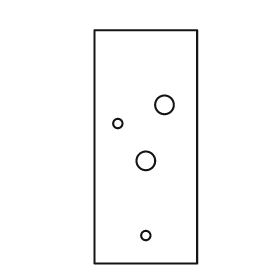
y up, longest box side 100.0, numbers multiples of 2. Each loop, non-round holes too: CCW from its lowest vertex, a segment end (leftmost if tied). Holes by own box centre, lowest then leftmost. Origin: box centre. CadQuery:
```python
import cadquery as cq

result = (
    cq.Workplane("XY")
    .moveTo(-22.0, -50.0)
    .lineTo(22.0, -50.0)
    .lineTo(22.0, 50.0)
    .lineTo(-22.0, 50.0)
    .close()
    .moveTo(0.0, -38.0)
    .circle(2.0)
    .moveTo(0.0, -6.0)
    .circle(4.0)
    .moveTo(-12.0, 10.0)
    .circle(2.0)
    .moveTo(8.0, 18.0)
    .circle(4.0)
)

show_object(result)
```